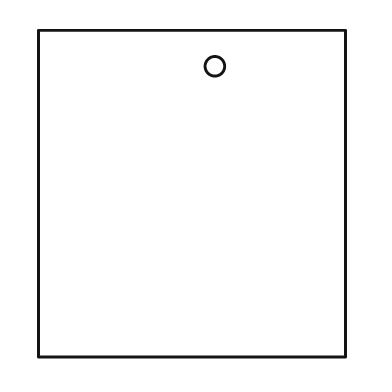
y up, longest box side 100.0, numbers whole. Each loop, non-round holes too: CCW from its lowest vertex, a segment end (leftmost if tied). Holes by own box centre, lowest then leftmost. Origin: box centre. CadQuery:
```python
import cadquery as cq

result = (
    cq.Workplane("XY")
    .moveTo(-47.0, -50.0)
    .lineTo(47.0, -50.0)
    .lineTo(47.0, 50.0)
    .lineTo(-47.0, 50.0)
    .close()
    .moveTo(7.0, 39.0)
    .circle(3.0)
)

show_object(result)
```